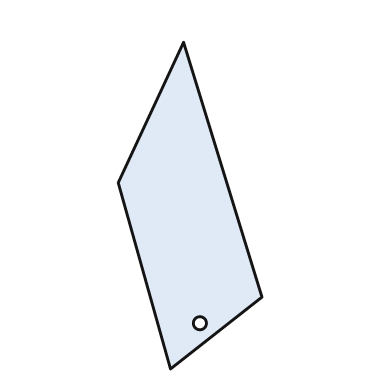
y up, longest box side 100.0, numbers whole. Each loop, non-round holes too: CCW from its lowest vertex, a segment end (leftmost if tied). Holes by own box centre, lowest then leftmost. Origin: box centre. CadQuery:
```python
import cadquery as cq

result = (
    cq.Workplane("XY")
    .moveTo(-6.0, -50.0)
    .lineTo(22.0, -28.0)
    .lineTo(-2.0, 50.0)
    .lineTo(-22.0, 7.0)
    .close()
    .moveTo(3.0, -36.0)
    .circle(2.0)
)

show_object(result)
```